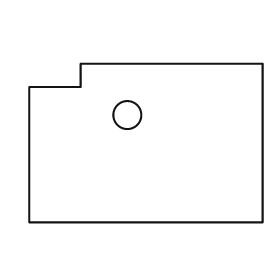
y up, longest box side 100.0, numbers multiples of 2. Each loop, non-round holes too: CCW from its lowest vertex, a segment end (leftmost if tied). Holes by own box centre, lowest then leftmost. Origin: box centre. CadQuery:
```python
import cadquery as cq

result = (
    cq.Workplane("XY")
    .moveTo(-50.0, -34.0)
    .lineTo(50.0, -34.0)
    .lineTo(50.0, 34.0)
    .lineTo(-28.0, 34.0)
    .lineTo(-28.0, 24.0)
    .lineTo(-50.0, 24.0)
    .close()
    .moveTo(-8.0, 12.0)
    .circle(6.0)
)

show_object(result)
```